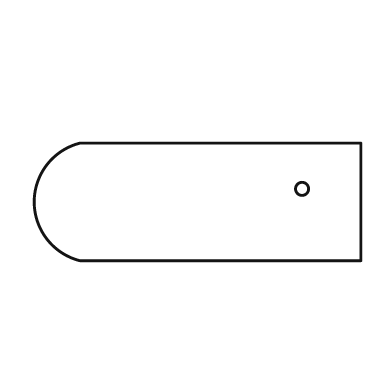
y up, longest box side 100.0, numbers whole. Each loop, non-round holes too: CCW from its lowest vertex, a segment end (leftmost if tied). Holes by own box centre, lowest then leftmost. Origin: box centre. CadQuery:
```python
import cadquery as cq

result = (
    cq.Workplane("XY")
    .moveTo(-36.0, -18.0)
    .lineTo(50.0, -18.0)
    .lineTo(50.0, 18.0)
    .lineTo(-36.0, 18.0)
    .threePointArc((-50.0, 0.0), (-36.0, -18.0))
    .close()
    .moveTo(32.0, 4.0)
    .circle(2.0)
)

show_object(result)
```